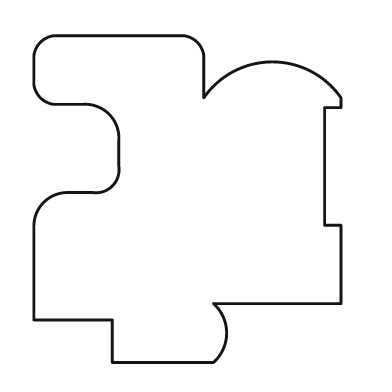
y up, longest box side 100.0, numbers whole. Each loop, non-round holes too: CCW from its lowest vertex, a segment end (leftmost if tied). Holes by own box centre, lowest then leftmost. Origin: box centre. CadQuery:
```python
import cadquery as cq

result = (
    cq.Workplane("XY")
    .moveTo(-23.0, -50.0)
    .lineTo(8.0, -50.0)
    .threePointArc((12.0, -41.0), (8.0, -32.0))
    .lineTo(47.0, -32.0)
    .lineTo(47.0, -8.0)
    .lineTo(42.0, -8.0)
    .lineTo(42.0, 28.0)
    .lineTo(47.0, 28.0)
    .lineTo(47.0, 31.0)
    .threePointArc((26.0, 42.0), (5.0, 31.0))
    .lineTo(5.0, 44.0)
    .threePointArc((3.0, 48.0), (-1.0, 50.0))
    .lineTo(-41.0, 50.0)
    .threePointArc((-45.0, 48.0), (-47.0, 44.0))
    .lineTo(-47.0, 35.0)
    .threePointArc((-45.0, 31.0), (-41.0, 29.0))
    .lineTo(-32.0, 29.0)
    .threePointArc((-24.0, 26.0), (-21.0, 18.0))
    .lineTo(-21.0, 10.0)
    .threePointArc((-23.0, 4.0), (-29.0, 2.0))
    .lineTo(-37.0, 2.0)
    .threePointArc((-44.0, -1.0), (-47.0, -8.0))
    .lineTo(-47.0, -37.0)
    .lineTo(-23.0, -37.0)
    .close()
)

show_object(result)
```